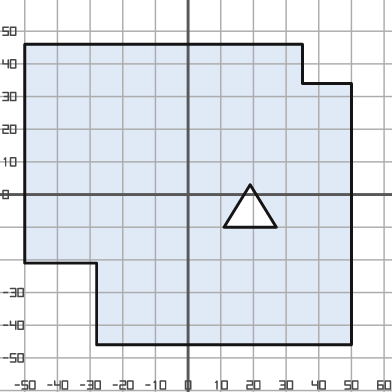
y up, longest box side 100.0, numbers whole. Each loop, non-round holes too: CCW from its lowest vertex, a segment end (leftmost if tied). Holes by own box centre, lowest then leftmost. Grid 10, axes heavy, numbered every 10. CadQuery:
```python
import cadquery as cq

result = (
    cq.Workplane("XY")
    .moveTo(-28.0, -46.0)
    .lineTo(50.0, -46.0)
    .lineTo(50.0, 34.0)
    .lineTo(35.0, 34.0)
    .lineTo(35.0, 46.0)
    .lineTo(-50.0, 46.0)
    .lineTo(-50.0, -21.0)
    .lineTo(-28.0, -21.0)
    .close()
    .moveTo(11.0, -10.0)
    .lineTo(27.0, -10.0)
    .lineTo(19.0, 3.0)
    .close()
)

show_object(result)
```